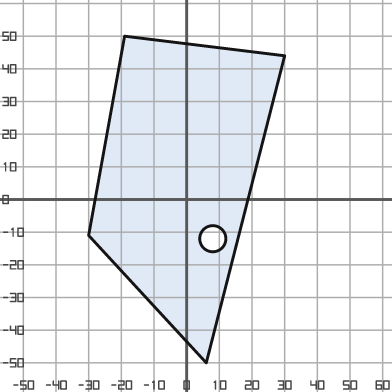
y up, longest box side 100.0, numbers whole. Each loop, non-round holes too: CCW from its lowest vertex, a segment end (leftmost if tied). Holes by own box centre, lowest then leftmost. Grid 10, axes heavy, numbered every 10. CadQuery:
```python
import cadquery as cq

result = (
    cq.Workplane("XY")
    .moveTo(6.0, -50.0)
    .lineTo(30.0, 44.0)
    .lineTo(-19.0, 50.0)
    .lineTo(-30.0, -11.0)
    .close()
    .moveTo(8.0, -12.0)
    .circle(4.0)
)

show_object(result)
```